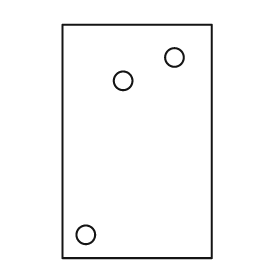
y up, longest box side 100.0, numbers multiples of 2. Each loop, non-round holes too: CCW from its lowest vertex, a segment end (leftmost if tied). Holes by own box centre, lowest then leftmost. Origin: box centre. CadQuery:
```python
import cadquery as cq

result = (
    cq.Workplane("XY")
    .moveTo(-32.0, -50.0)
    .lineTo(32.0, -50.0)
    .lineTo(32.0, 50.0)
    .lineTo(-32.0, 50.0)
    .close()
    .moveTo(-22.0, -40.0)
    .circle(4.0)
    .moveTo(-6.0, 26.0)
    .circle(4.0)
    .moveTo(16.0, 36.0)
    .circle(4.0)
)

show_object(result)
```